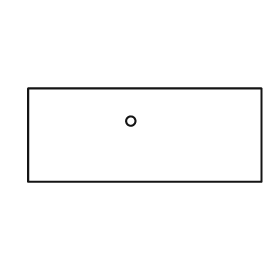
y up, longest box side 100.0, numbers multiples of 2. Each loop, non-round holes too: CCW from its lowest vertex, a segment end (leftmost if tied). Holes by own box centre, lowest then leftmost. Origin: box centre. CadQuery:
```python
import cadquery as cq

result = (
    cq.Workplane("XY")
    .moveTo(-50.0, -20.0)
    .lineTo(50.0, -20.0)
    .lineTo(50.0, 20.0)
    .lineTo(-50.0, 20.0)
    .close()
    .moveTo(-6.0, 6.0)
    .circle(2.0)
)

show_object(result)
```